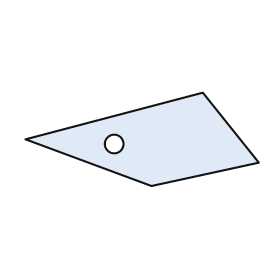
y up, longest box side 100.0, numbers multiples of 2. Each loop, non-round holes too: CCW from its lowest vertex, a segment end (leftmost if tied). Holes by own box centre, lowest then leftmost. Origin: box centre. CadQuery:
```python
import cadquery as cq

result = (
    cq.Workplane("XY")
    .moveTo(4.0, -20.0)
    .lineTo(50.0, -10.0)
    .lineTo(26.0, 20.0)
    .lineTo(-50.0, 0.0)
    .close()
    .moveTo(-12.0, -2.0)
    .circle(4.0)
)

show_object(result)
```